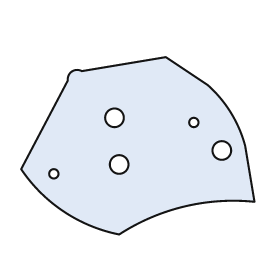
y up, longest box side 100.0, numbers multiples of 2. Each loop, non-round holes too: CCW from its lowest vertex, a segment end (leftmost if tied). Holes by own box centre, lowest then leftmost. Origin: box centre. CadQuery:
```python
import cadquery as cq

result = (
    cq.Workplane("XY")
    .moveTo(-8.0, -38.0)
    .threePointArc((20.0, -26.0), (50.0, -24.0))
    .lineTo(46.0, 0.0)
    .threePointArc((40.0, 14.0), (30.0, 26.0))
    .lineTo(12.0, 38.0)
    .lineTo(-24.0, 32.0)
    .threePointArc((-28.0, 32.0), (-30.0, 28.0))
    .lineTo(-50.0, -10.0)
    .threePointArc((-32.0, -28.0), (-8.0, -38.0))
    .close()
    .moveTo(-36.0, -12.0)
    .circle(2.0)
    .moveTo(-8.0, -8.0)
    .circle(4.0)
    .moveTo(36.0, -2.0)
    .circle(4.0)
    .moveTo(24.0, 10.0)
    .circle(2.0)
    .moveTo(-10.0, 12.0)
    .circle(4.0)
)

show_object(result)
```